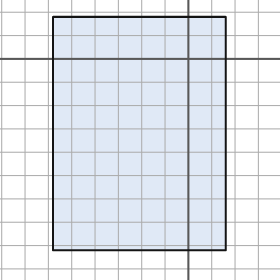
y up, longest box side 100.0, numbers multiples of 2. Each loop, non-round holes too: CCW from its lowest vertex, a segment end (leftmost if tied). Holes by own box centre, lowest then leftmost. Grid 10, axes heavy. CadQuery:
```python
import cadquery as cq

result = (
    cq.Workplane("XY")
    .moveTo(-58.0, -82.0)
    .lineTo(16.0, -82.0)
    .lineTo(16.0, 18.0)
    .lineTo(-58.0, 18.0)
    .close()
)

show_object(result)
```